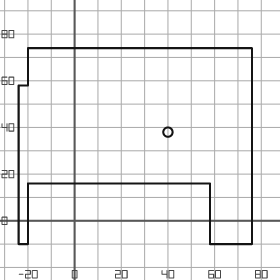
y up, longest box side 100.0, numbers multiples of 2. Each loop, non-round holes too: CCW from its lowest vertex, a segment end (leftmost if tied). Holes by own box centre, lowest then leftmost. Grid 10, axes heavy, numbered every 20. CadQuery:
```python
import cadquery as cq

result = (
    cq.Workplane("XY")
    .moveTo(-24.0, -10.0)
    .lineTo(-20.0, -10.0)
    .lineTo(-20.0, 16.0)
    .lineTo(58.0, 16.0)
    .lineTo(58.0, -10.0)
    .lineTo(76.0, -10.0)
    .lineTo(76.0, 74.0)
    .lineTo(-20.0, 74.0)
    .lineTo(-20.0, 58.0)
    .lineTo(-24.0, 58.0)
    .close()
    .moveTo(40.0, 38.0)
    .circle(2.0)
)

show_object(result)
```